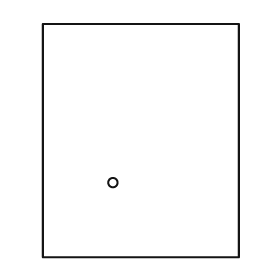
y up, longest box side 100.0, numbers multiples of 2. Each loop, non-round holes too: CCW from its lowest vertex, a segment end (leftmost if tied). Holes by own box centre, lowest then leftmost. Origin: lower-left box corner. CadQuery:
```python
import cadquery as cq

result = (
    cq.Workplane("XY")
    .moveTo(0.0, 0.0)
    .lineTo(84.0, 0.0)
    .lineTo(84.0, 100.0)
    .lineTo(0.0, 100.0)
    .close()
    .moveTo(30.0, 32.0)
    .circle(2.0)
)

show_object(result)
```